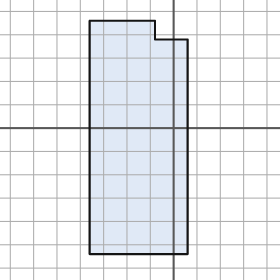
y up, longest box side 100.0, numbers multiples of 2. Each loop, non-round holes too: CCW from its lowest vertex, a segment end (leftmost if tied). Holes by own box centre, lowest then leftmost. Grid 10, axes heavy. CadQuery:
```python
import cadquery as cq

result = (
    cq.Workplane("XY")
    .moveTo(-36.0, -54.0)
    .lineTo(6.0, -54.0)
    .lineTo(6.0, 38.0)
    .lineTo(-8.0, 38.0)
    .lineTo(-8.0, 46.0)
    .lineTo(-36.0, 46.0)
    .close()
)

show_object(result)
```